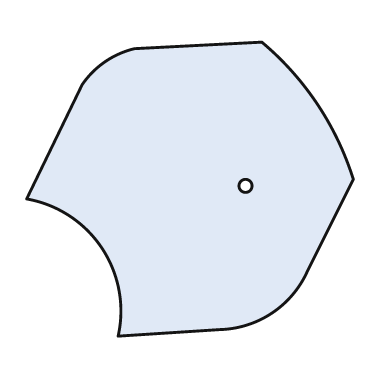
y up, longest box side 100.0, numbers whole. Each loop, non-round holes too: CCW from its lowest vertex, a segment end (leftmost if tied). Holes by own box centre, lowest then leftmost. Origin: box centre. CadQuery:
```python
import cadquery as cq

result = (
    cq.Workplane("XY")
    .moveTo(-22.0, -45.0)
    .lineTo(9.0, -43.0)
    .threePointArc((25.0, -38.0), (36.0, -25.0))
    .lineTo(50.0, 3.0)
    .threePointArc((39.0, 26.0), (22.0, 45.0))
    .lineTo(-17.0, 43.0)
    .threePointArc((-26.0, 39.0), (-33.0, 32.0))
    .lineTo(-50.0, -3.0)
    .threePointArc((-27.0, -18.0), (-22.0, -45.0))
    .close()
    .moveTo(17.0, 1.0)
    .circle(2.0)
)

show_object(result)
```